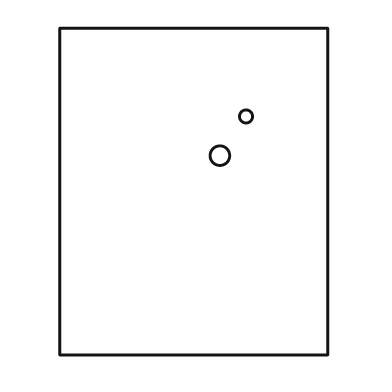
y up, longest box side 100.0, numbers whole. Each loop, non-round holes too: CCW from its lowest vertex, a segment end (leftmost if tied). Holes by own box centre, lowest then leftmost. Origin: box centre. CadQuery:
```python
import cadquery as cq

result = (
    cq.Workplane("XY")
    .moveTo(-41.0, -50.0)
    .lineTo(41.0, -50.0)
    .lineTo(41.0, 50.0)
    .lineTo(-41.0, 50.0)
    .close()
    .moveTo(8.0, 11.0)
    .circle(3.0)
    .moveTo(16.0, 23.0)
    .circle(2.0)
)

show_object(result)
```